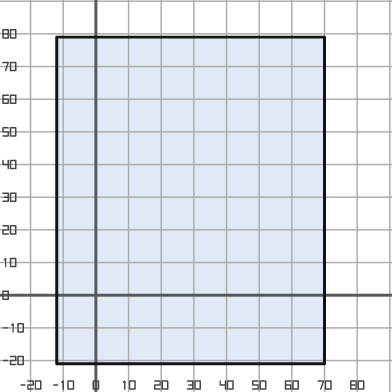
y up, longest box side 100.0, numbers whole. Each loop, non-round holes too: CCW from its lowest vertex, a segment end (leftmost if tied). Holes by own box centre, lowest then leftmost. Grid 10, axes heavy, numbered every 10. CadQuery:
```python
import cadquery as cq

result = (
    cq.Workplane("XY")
    .moveTo(-12.0, -21.0)
    .lineTo(70.0, -21.0)
    .lineTo(70.0, 79.0)
    .lineTo(-12.0, 79.0)
    .close()
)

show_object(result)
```